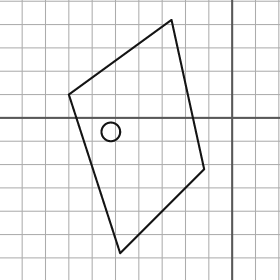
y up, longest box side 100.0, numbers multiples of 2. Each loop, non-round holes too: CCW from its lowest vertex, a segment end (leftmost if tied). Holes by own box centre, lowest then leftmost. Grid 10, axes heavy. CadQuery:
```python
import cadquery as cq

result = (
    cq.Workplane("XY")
    .moveTo(-48.0, -58.0)
    .lineTo(-12.0, -22.0)
    .lineTo(-26.0, 42.0)
    .lineTo(-70.0, 10.0)
    .close()
    .moveTo(-52.0, -6.0)
    .circle(4.0)
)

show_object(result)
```